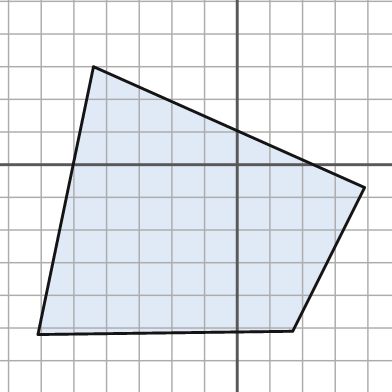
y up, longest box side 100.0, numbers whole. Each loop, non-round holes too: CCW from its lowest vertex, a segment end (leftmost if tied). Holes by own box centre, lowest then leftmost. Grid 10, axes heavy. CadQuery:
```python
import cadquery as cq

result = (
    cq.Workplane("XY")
    .moveTo(-61.0, -52.0)
    .lineTo(17.0, -51.0)
    .lineTo(39.0, -7.0)
    .lineTo(-44.0, 30.0)
    .close()
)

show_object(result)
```